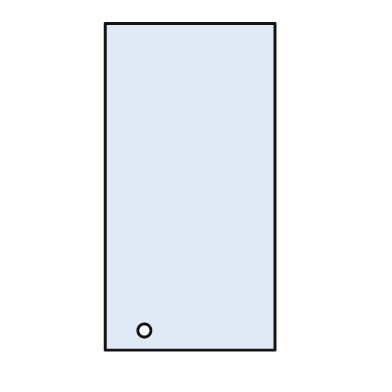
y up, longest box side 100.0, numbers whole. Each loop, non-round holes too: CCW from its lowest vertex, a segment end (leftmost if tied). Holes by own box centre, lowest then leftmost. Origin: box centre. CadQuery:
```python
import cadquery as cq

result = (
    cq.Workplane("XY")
    .moveTo(-26.0, -50.0)
    .lineTo(26.0, -50.0)
    .lineTo(26.0, 50.0)
    .lineTo(-26.0, 50.0)
    .close()
    .moveTo(-14.0, -44.0)
    .circle(2.0)
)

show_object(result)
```